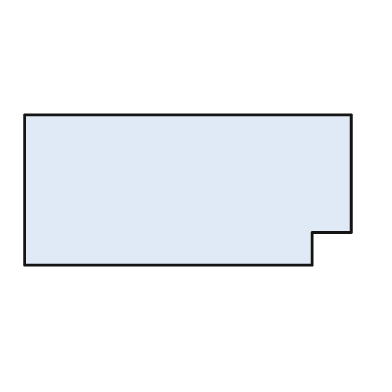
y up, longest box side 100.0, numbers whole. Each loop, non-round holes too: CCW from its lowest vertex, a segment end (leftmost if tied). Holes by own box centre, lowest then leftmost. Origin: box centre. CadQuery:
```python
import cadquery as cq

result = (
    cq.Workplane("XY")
    .moveTo(-50.0, -23.0)
    .lineTo(38.0, -23.0)
    .lineTo(38.0, -13.0)
    .lineTo(50.0, -13.0)
    .lineTo(50.0, 23.0)
    .lineTo(-50.0, 23.0)
    .close()
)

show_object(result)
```